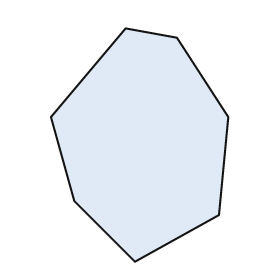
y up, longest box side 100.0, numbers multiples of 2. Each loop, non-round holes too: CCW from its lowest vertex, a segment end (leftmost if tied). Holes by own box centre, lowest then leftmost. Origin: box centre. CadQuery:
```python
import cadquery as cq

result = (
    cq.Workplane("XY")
    .moveTo(-2.0, -50.0)
    .lineTo(34.0, -30.0)
    .lineTo(38.0, 12.0)
    .lineTo(16.0, 46.0)
    .lineTo(-6.0, 50.0)
    .lineTo(-38.0, 12.0)
    .lineTo(-28.0, -24.0)
    .close()
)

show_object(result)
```